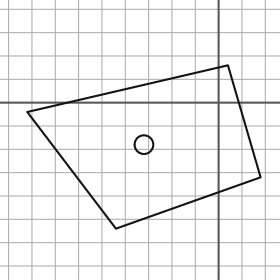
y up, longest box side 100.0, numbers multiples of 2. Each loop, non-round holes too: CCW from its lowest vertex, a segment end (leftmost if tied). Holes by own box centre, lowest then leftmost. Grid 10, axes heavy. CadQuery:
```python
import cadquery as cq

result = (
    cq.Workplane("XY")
    .moveTo(-44.0, -54.0)
    .lineTo(18.0, -32.0)
    .lineTo(4.0, 16.0)
    .lineTo(-82.0, -4.0)
    .close()
    .moveTo(-32.0, -18.0)
    .circle(4.0)
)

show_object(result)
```